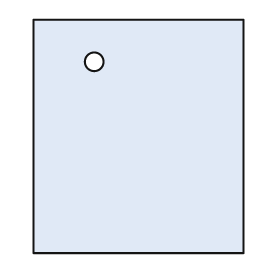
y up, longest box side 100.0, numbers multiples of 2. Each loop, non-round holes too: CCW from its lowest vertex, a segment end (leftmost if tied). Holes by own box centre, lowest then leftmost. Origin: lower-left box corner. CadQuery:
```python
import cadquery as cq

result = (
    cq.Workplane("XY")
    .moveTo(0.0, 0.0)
    .lineTo(90.0, 0.0)
    .lineTo(90.0, 100.0)
    .lineTo(0.0, 100.0)
    .close()
    .moveTo(26.0, 82.0)
    .circle(4.0)
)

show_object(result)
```